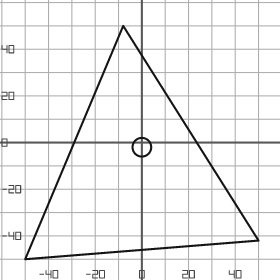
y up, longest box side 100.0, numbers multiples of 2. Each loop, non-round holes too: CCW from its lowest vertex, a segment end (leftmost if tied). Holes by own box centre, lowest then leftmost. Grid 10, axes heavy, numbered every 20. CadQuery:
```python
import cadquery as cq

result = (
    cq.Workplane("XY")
    .moveTo(-50.0, -50.0)
    .lineTo(50.0, -42.0)
    .lineTo(-8.0, 50.0)
    .close()
    .moveTo(0.0, -2.0)
    .circle(4.0)
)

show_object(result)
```